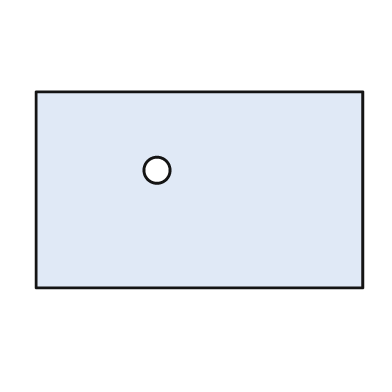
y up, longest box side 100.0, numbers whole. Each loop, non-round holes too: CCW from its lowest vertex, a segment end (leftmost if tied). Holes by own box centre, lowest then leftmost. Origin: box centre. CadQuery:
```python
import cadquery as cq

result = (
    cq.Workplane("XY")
    .moveTo(-50.0, -30.0)
    .lineTo(50.0, -30.0)
    .lineTo(50.0, 30.0)
    .lineTo(-50.0, 30.0)
    .close()
    .moveTo(-13.0, 6.0)
    .circle(4.0)
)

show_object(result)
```